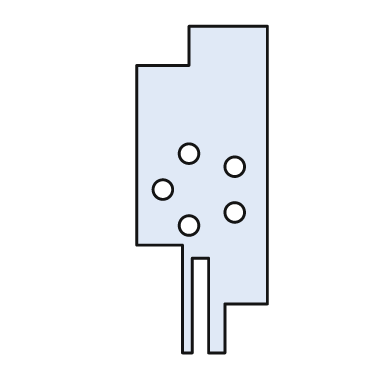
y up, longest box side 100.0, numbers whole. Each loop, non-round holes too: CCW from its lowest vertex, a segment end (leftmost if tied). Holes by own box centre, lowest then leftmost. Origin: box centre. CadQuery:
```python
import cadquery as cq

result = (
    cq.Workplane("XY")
    .moveTo(-6.0, -50.0)
    .lineTo(-3.0, -50.0)
    .lineTo(-3.0, -21.0)
    .lineTo(2.0, -21.0)
    .lineTo(2.0, -50.0)
    .lineTo(7.0, -50.0)
    .lineTo(7.0, -35.0)
    .lineTo(20.0, -35.0)
    .lineTo(20.0, 50.0)
    .lineTo(-4.0, 50.0)
    .lineTo(-4.0, 38.0)
    .lineTo(-20.0, 38.0)
    .lineTo(-20.0, -17.0)
    .lineTo(-6.0, -17.0)
    .close()
    .moveTo(-4.0, -11.0)
    .circle(3.0)
    .moveTo(10.0, -7.0)
    .circle(3.0)
    .moveTo(-12.0, 0.0)
    .circle(3.0)
    .moveTo(10.0, 7.0)
    .circle(3.0)
    .moveTo(-4.0, 11.0)
    .circle(3.0)
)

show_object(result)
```